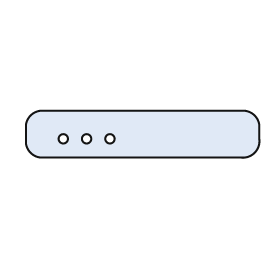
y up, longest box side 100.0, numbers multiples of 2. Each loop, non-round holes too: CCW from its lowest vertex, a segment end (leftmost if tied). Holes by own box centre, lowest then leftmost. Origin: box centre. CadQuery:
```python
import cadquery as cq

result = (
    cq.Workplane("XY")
    .moveTo(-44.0, -10.0)
    .lineTo(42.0, -10.0)
    .threePointArc((48.0, -8.0), (50.0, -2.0))
    .lineTo(50.0, 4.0)
    .threePointArc((48.0, 8.0), (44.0, 10.0))
    .lineTo(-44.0, 10.0)
    .threePointArc((-48.0, 8.0), (-50.0, 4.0))
    .lineTo(-50.0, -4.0)
    .threePointArc((-48.0, -8.0), (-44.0, -10.0))
    .close()
    .moveTo(-34.0, -2.0)
    .circle(2.0)
    .moveTo(-24.0, -2.0)
    .circle(2.0)
    .moveTo(-14.0, -2.0)
    .circle(2.0)
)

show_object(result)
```